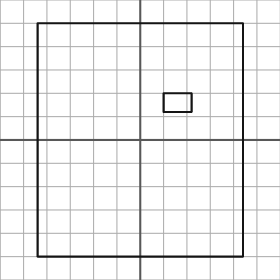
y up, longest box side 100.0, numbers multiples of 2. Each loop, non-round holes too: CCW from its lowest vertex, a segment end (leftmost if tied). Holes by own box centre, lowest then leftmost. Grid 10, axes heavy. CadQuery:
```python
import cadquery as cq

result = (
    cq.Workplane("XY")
    .moveTo(-44.0, -50.0)
    .lineTo(44.0, -50.0)
    .lineTo(44.0, 50.0)
    .lineTo(-44.0, 50.0)
    .close()
    .moveTo(10.0, 12.0)
    .lineTo(22.0, 12.0)
    .lineTo(22.0, 20.0)
    .lineTo(10.0, 20.0)
    .close()
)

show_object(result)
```